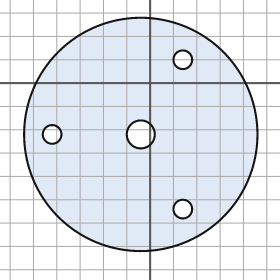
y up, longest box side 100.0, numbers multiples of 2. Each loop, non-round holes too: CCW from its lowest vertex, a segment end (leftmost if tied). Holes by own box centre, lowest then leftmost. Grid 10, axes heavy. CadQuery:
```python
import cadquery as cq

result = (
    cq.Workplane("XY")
    .moveTo(-4.0, -22.0)
    .circle(50.0)
    .moveTo(14.0, -54.0)
    .circle(4.0)
    .moveTo(-42.0, -22.0)
    .circle(4.0)
    .moveTo(-4.0, -22.0)
    .circle(6.0)
    .moveTo(14.0, 10.0)
    .circle(4.0)
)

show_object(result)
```